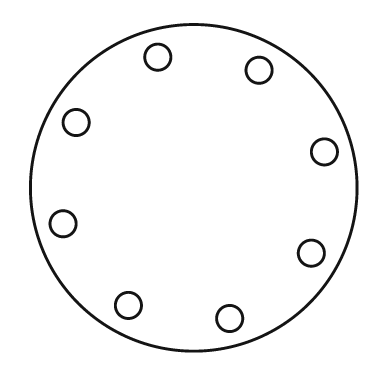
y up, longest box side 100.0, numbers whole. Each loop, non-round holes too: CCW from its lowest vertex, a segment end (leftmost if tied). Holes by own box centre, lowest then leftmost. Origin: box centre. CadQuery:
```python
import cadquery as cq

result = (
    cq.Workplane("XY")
    .moveTo(0.0, 0.0)
    .circle(50.0)
    .moveTo(11.0, -40.0)
    .circle(4.0)
    .moveTo(-20.0, -36.0)
    .circle(4.0)
    .moveTo(36.0, -20.0)
    .circle(4.0)
    .moveTo(-40.0, -11.0)
    .circle(4.0)
    .moveTo(40.0, 11.0)
    .circle(4.0)
    .moveTo(-36.0, 20.0)
    .circle(4.0)
    .moveTo(20.0, 36.0)
    .circle(4.0)
    .moveTo(-11.0, 40.0)
    .circle(4.0)
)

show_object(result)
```